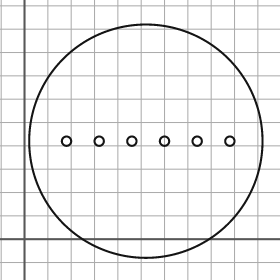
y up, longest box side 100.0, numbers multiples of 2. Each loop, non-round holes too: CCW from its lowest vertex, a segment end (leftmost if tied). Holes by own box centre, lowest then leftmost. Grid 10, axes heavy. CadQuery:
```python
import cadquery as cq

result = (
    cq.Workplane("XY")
    .moveTo(52.0, 42.0)
    .circle(50.0)
    .moveTo(18.0, 42.0)
    .circle(2.0)
    .moveTo(32.0, 42.0)
    .circle(2.0)
    .moveTo(46.0, 42.0)
    .circle(2.0)
    .moveTo(60.0, 42.0)
    .circle(2.0)
    .moveTo(74.0, 42.0)
    .circle(2.0)
    .moveTo(88.0, 42.0)
    .circle(2.0)
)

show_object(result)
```